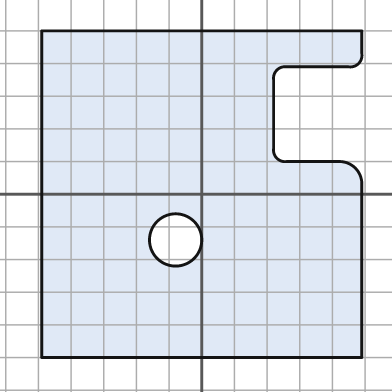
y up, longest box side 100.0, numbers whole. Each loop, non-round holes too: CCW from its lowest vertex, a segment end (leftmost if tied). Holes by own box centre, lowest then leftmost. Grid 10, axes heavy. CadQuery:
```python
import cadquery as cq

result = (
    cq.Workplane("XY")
    .moveTo(-49.0, -50.0)
    .lineTo(49.0, -50.0)
    .lineTo(49.0, 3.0)
    .threePointArc((47.0, 8.0), (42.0, 10.0))
    .lineTo(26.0, 10.0)
    .threePointArc((23.0, 11.0), (22.0, 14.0))
    .lineTo(22.0, 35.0)
    .threePointArc((23.0, 38.0), (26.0, 39.0))
    .lineTo(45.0, 39.0)
    .threePointArc((48.0, 40.0), (49.0, 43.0))
    .lineTo(49.0, 50.0)
    .lineTo(-49.0, 50.0)
    .close()
    .moveTo(-8.0, -14.0)
    .circle(8.0)
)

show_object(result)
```